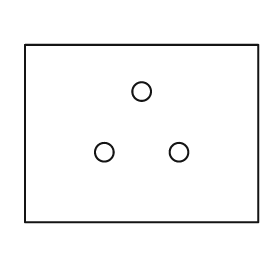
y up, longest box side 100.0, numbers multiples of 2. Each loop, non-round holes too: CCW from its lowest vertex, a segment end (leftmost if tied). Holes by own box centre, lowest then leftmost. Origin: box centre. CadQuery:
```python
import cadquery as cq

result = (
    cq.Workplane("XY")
    .moveTo(-50.0, -38.0)
    .lineTo(50.0, -38.0)
    .lineTo(50.0, 38.0)
    .lineTo(-50.0, 38.0)
    .close()
    .moveTo(-16.0, -8.0)
    .circle(4.0)
    .moveTo(16.0, -8.0)
    .circle(4.0)
    .moveTo(0.0, 18.0)
    .circle(4.0)
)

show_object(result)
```